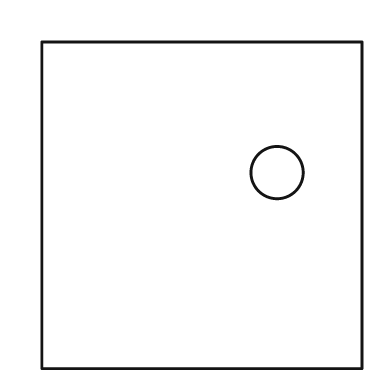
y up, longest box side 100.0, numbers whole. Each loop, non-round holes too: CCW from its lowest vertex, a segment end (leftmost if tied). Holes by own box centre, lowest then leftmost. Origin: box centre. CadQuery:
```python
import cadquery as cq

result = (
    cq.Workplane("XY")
    .moveTo(-49.0, -50.0)
    .lineTo(49.0, -50.0)
    .lineTo(49.0, 50.0)
    .lineTo(-49.0, 50.0)
    .close()
    .moveTo(23.0, 10.0)
    .circle(8.0)
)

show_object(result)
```